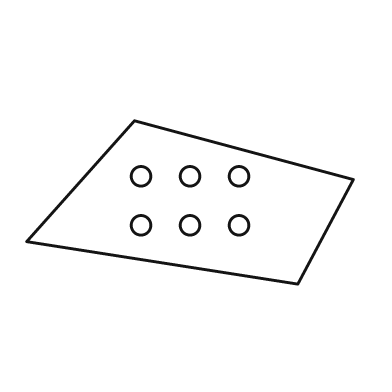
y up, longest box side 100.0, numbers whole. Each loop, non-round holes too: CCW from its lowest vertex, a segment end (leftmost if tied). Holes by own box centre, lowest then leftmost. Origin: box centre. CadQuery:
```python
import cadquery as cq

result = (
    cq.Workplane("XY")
    .moveTo(33.0, -25.0)
    .lineTo(50.0, 7.0)
    .lineTo(-17.0, 25.0)
    .lineTo(-50.0, -12.0)
    .close()
    .moveTo(-15.0, -7.0)
    .circle(3.0)
    .moveTo(0.0, -7.0)
    .circle(3.0)
    .moveTo(15.0, -7.0)
    .circle(3.0)
    .moveTo(-15.0, 8.0)
    .circle(3.0)
    .moveTo(0.0, 8.0)
    .circle(3.0)
    .moveTo(15.0, 8.0)
    .circle(3.0)
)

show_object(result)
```